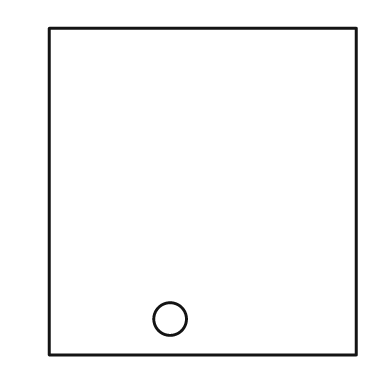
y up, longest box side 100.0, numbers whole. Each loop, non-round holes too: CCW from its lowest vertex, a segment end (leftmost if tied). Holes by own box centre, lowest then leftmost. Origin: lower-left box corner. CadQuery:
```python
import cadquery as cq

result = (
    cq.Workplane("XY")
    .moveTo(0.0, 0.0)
    .lineTo(94.0, 0.0)
    .lineTo(94.0, 100.0)
    .lineTo(0.0, 100.0)
    .close()
    .moveTo(37.0, 11.0)
    .circle(5.0)
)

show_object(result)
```